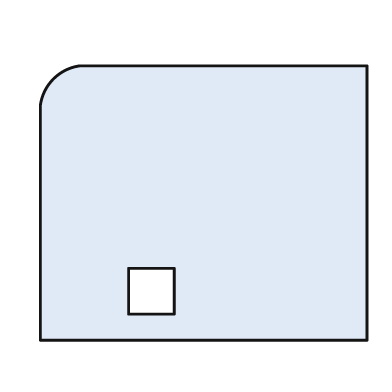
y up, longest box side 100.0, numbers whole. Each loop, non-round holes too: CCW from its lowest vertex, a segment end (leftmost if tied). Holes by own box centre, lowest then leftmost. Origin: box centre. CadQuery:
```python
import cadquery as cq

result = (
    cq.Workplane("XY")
    .moveTo(-50.0, -42.0)
    .lineTo(50.0, -42.0)
    .lineTo(50.0, 42.0)
    .lineTo(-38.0, 42.0)
    .threePointArc((-46.0, 38.0), (-50.0, 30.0))
    .close()
    .moveTo(-23.0, -34.0)
    .lineTo(-9.0, -34.0)
    .lineTo(-9.0, -20.0)
    .lineTo(-23.0, -20.0)
    .close()
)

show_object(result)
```